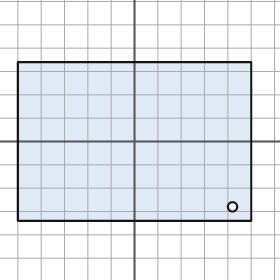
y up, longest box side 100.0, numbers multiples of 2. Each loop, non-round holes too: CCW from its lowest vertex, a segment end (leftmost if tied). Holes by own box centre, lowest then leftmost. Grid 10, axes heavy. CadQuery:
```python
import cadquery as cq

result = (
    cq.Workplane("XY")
    .moveTo(-50.0, -34.0)
    .lineTo(50.0, -34.0)
    .lineTo(50.0, 34.0)
    .lineTo(-50.0, 34.0)
    .close()
    .moveTo(42.0, -28.0)
    .circle(2.0)
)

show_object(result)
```